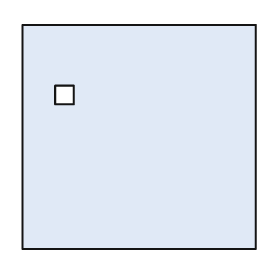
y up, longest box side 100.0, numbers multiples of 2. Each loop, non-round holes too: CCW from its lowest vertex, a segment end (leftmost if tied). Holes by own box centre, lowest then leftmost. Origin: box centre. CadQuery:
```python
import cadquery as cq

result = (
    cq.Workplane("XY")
    .moveTo(-50.0, -48.0)
    .lineTo(50.0, -48.0)
    .lineTo(50.0, 48.0)
    .lineTo(-50.0, 48.0)
    .close()
    .moveTo(-36.0, 14.0)
    .lineTo(-28.0, 14.0)
    .lineTo(-28.0, 22.0)
    .lineTo(-36.0, 22.0)
    .close()
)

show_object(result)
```